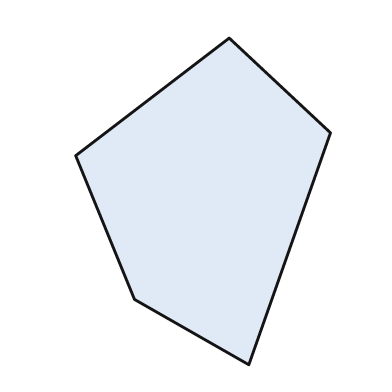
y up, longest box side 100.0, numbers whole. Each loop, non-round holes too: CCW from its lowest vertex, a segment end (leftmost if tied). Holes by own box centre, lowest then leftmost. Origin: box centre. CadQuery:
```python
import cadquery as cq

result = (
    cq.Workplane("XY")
    .moveTo(14.0, -50.0)
    .lineTo(39.0, 21.0)
    .lineTo(8.0, 50.0)
    .lineTo(-39.0, 14.0)
    .lineTo(-21.0, -30.0)
    .close()
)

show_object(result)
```